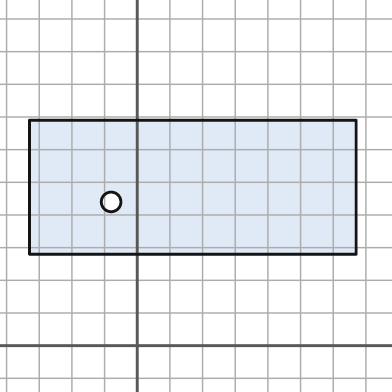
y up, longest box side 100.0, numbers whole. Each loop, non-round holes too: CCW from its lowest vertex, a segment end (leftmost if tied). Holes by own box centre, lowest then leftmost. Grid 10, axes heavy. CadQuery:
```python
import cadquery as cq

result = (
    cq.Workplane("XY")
    .moveTo(-33.0, 28.0)
    .lineTo(67.0, 28.0)
    .lineTo(67.0, 69.0)
    .lineTo(-33.0, 69.0)
    .close()
    .moveTo(-8.0, 44.0)
    .circle(3.0)
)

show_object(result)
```